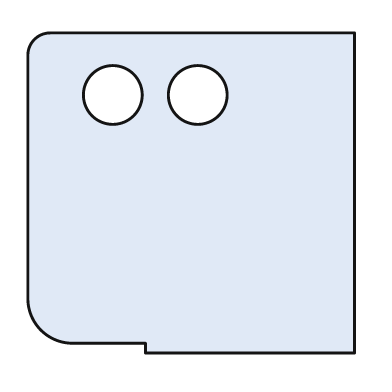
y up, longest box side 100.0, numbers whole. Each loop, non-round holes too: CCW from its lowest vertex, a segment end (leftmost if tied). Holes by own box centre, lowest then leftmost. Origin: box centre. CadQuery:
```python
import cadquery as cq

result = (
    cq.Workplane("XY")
    .moveTo(-14.0, -49.0)
    .lineTo(50.0, -49.0)
    .lineTo(50.0, 49.0)
    .lineTo(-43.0, 49.0)
    .threePointArc((-48.0, 47.0), (-50.0, 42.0))
    .lineTo(-50.0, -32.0)
    .threePointArc((-46.0, -42.0), (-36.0, -46.0))
    .lineTo(-14.0, -46.0)
    .close()
    .moveTo(-24.0, 30.0)
    .circle(9.0)
    .moveTo(2.0, 30.0)
    .circle(9.0)
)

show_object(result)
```